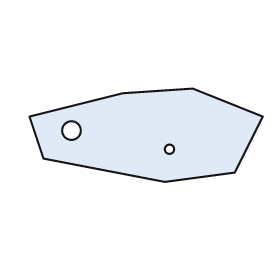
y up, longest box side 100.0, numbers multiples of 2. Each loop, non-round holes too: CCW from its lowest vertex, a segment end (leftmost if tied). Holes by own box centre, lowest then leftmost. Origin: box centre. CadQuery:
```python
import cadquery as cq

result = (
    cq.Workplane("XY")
    .moveTo(8.0, -20.0)
    .lineTo(38.0, -16.0)
    .lineTo(50.0, 8.0)
    .lineTo(20.0, 20.0)
    .lineTo(-10.0, 18.0)
    .lineTo(-50.0, 8.0)
    .lineTo(-44.0, -10.0)
    .close()
    .moveTo(10.0, -6.0)
    .circle(2.0)
    .moveTo(-32.0, 2.0)
    .circle(4.0)
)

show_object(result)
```